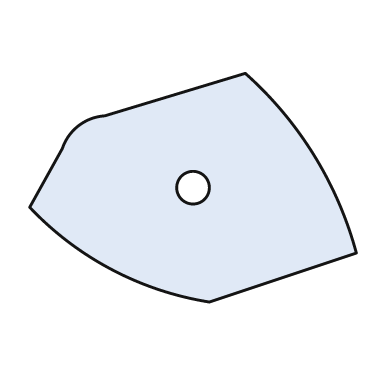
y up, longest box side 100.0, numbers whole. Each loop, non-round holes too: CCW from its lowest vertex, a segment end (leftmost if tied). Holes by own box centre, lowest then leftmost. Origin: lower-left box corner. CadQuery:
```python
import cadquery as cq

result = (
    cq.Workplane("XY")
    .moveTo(55.0, 0.0)
    .lineTo(100.0, 15.0)
    .threePointArc((87.0, 45.0), (66.0, 70.0))
    .lineTo(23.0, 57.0)
    .threePointArc((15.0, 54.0), (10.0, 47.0))
    .lineTo(0.0, 29.0)
    .threePointArc((25.0, 10.0), (55.0, 0.0))
    .close()
    .moveTo(50.0, 35.0)
    .circle(5.0)
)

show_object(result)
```